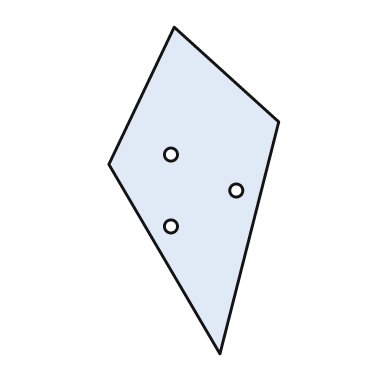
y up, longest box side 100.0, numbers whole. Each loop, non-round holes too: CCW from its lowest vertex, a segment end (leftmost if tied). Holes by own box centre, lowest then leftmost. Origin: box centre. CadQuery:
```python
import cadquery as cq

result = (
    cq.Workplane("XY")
    .moveTo(8.0, -50.0)
    .lineTo(26.0, 21.0)
    .lineTo(-6.0, 50.0)
    .lineTo(-26.0, 8.0)
    .close()
    .moveTo(-7.0, -11.0)
    .circle(2.0)
    .moveTo(13.0, 0.0)
    .circle(2.0)
    .moveTo(-7.0, 11.0)
    .circle(2.0)
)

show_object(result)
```